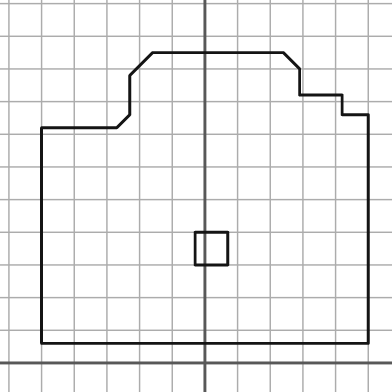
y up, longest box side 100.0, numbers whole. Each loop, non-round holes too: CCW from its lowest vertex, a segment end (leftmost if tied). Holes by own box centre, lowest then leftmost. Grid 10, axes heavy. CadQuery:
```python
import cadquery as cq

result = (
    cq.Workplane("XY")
    .moveTo(-50.0, 6.0)
    .lineTo(50.0, 6.0)
    .lineTo(50.0, 76.0)
    .lineTo(42.0, 76.0)
    .lineTo(42.0, 82.0)
    .lineTo(29.0, 82.0)
    .lineTo(29.0, 90.0)
    .lineTo(24.0, 95.0)
    .lineTo(-16.0, 95.0)
    .lineTo(-23.0, 88.0)
    .lineTo(-23.0, 76.0)
    .lineTo(-27.0, 72.0)
    .lineTo(-50.0, 72.0)
    .close()
    .moveTo(-3.0, 30.0)
    .lineTo(7.0, 30.0)
    .lineTo(7.0, 40.0)
    .lineTo(-3.0, 40.0)
    .close()
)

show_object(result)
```